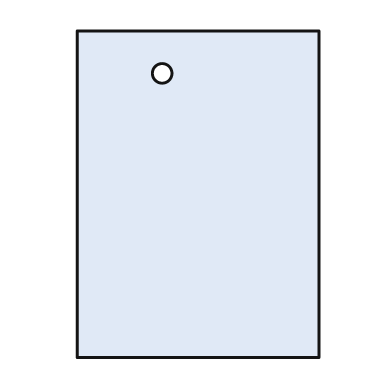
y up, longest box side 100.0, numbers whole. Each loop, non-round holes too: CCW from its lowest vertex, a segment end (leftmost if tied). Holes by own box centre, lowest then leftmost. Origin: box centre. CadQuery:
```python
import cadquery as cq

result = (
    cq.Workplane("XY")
    .moveTo(-37.0, -50.0)
    .lineTo(37.0, -50.0)
    .lineTo(37.0, 50.0)
    .lineTo(-37.0, 50.0)
    .close()
    .moveTo(-11.0, 37.0)
    .circle(3.0)
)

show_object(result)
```